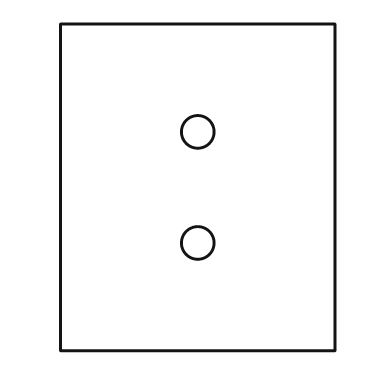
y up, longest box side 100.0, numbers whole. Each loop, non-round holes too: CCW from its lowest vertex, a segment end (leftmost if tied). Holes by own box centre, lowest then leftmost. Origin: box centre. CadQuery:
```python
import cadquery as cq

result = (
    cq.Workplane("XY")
    .moveTo(-42.0, -50.0)
    .lineTo(42.0, -50.0)
    .lineTo(42.0, 50.0)
    .lineTo(-42.0, 50.0)
    .close()
    .moveTo(0.0, -17.0)
    .circle(5.0)
    .moveTo(0.0, 17.0)
    .circle(5.0)
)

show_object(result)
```